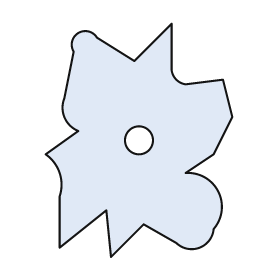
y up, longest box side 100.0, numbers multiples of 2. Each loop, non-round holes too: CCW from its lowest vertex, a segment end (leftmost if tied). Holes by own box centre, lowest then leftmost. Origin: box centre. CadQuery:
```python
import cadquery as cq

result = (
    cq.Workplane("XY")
    .moveTo(-12.0, -50.0)
    .lineTo(2.0, -36.0)
    .lineTo(16.0, -44.0)
    .threePointArc((26.0, -46.0), (32.0, -38.0))
    .threePointArc((34.0, -22.0), (20.0, -14.0))
    .lineTo(32.0, -6.0)
    .lineTo(40.0, 10.0)
    .lineTo(36.0, 26.0)
    .lineTo(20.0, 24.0)
    .threePointArc((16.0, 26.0), (14.0, 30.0))
    .lineTo(14.0, 50.0)
    .lineTo(-2.0, 34.0)
    .lineTo(-18.0, 44.0)
    .threePointArc((-26.0, 46.0), (-28.0, 38.0))
    .lineTo(-32.0, 18.0)
    .threePointArc((-32.0, 10.0), (-26.0, 4.0))
    .lineTo(-40.0, -6.0)
    .threePointArc((-34.0, -14.0), (-34.0, -24.0))
    .lineTo(-34.0, -46.0)
    .lineTo(-14.0, -30.0)
    .close()
    .moveTo(0.0, 0.0)
    .circle(6.0)
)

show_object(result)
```